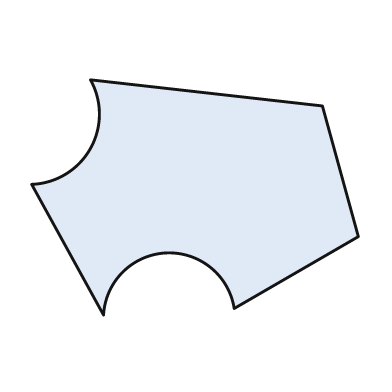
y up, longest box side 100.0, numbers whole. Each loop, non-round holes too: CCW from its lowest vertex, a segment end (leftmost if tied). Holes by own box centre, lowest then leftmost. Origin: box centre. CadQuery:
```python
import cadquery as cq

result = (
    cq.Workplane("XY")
    .moveTo(-28.0, -36.0)
    .threePointArc((-9.0, -17.0), (12.0, -34.0))
    .lineTo(50.0, -12.0)
    .lineTo(39.0, 28.0)
    .lineTo(-32.0, 36.0)
    .threePointArc((-32.0, 15.0), (-50.0, 4.0))
    .close()
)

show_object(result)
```